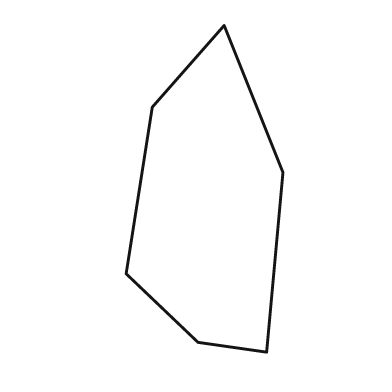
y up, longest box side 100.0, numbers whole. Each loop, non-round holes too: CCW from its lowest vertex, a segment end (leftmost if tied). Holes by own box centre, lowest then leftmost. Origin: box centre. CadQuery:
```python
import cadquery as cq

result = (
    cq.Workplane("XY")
    .moveTo(19.0, -50.0)
    .lineTo(24.0, 5.0)
    .lineTo(6.0, 50.0)
    .lineTo(-16.0, 25.0)
    .lineTo(-24.0, -26.0)
    .lineTo(-2.0, -47.0)
    .close()
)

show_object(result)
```